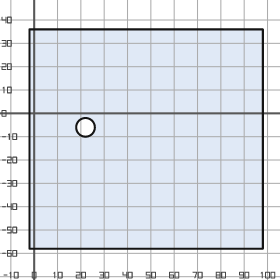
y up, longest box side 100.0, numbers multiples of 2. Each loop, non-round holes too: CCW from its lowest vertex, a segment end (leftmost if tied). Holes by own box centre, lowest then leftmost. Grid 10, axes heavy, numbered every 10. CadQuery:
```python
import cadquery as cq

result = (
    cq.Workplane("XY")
    .moveTo(-2.0, -58.0)
    .lineTo(98.0, -58.0)
    .lineTo(98.0, 36.0)
    .lineTo(-2.0, 36.0)
    .close()
    .moveTo(22.0, -6.0)
    .circle(4.0)
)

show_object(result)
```